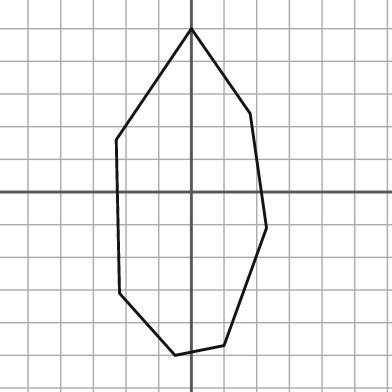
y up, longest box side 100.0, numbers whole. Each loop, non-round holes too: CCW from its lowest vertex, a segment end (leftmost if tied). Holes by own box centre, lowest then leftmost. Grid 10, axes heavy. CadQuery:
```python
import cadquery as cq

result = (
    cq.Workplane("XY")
    .moveTo(-5.0, -50.0)
    .lineTo(10.0, -47.0)
    .lineTo(23.0, -11.0)
    .lineTo(18.0, 24.0)
    .lineTo(0.0, 50.0)
    .lineTo(-23.0, 16.0)
    .lineTo(-22.0, -31.0)
    .close()
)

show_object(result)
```